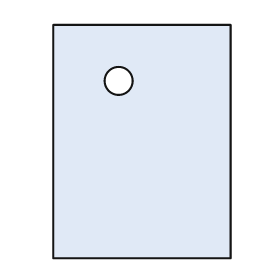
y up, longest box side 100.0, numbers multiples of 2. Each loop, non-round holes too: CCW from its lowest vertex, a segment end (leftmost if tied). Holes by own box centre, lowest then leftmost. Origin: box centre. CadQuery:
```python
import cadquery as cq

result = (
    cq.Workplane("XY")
    .moveTo(-38.0, -50.0)
    .lineTo(38.0, -50.0)
    .lineTo(38.0, 50.0)
    .lineTo(-38.0, 50.0)
    .close()
    .moveTo(-10.0, 26.0)
    .circle(6.0)
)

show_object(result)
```